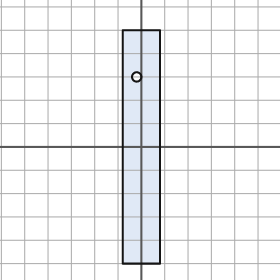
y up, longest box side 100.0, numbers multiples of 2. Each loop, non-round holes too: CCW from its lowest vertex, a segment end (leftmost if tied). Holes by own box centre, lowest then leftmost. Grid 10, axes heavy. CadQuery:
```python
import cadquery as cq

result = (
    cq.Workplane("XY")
    .moveTo(-8.0, -50.0)
    .lineTo(8.0, -50.0)
    .lineTo(8.0, 50.0)
    .lineTo(-8.0, 50.0)
    .close()
    .moveTo(-2.0, 30.0)
    .circle(2.0)
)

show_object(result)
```